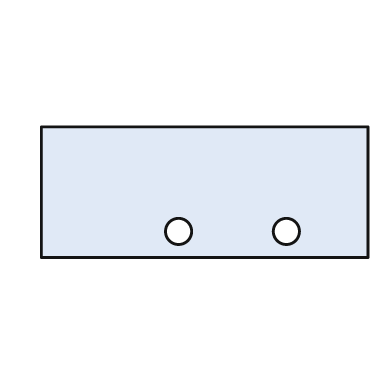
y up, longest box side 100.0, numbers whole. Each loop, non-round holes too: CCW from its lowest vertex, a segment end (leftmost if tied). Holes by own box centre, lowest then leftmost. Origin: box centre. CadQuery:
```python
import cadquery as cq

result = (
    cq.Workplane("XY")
    .moveTo(-50.0, -20.0)
    .lineTo(50.0, -20.0)
    .lineTo(50.0, 20.0)
    .lineTo(-50.0, 20.0)
    .close()
    .moveTo(-8.0, -12.0)
    .circle(4.0)
    .moveTo(25.0, -12.0)
    .circle(4.0)
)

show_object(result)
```